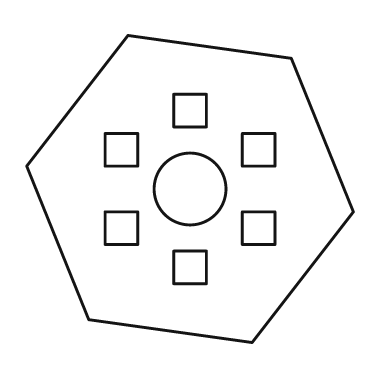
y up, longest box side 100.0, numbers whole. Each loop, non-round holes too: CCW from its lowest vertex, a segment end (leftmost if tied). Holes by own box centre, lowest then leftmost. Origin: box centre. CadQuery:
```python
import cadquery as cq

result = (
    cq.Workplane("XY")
    .moveTo(19.0, -47.0)
    .lineTo(50.0, -7.0)
    .lineTo(31.0, 40.0)
    .lineTo(-19.0, 47.0)
    .lineTo(-50.0, 7.0)
    .lineTo(-31.0, -40.0)
    .close()
    .moveTo(-5.0, -29.0)
    .lineTo(5.0, -29.0)
    .lineTo(5.0, -19.0)
    .lineTo(-5.0, -19.0)
    .close()
    .moveTo(-26.0, -17.0)
    .lineTo(-16.0, -17.0)
    .lineTo(-16.0, -7.0)
    .lineTo(-26.0, -7.0)
    .close()
    .moveTo(16.0, -17.0)
    .lineTo(26.0, -17.0)
    .lineTo(26.0, -7.0)
    .lineTo(16.0, -7.0)
    .close()
    .moveTo(0.0, 0.0)
    .circle(11.0)
    .moveTo(-26.0, 7.0)
    .lineTo(-16.0, 7.0)
    .lineTo(-16.0, 17.0)
    .lineTo(-26.0, 17.0)
    .close()
    .moveTo(16.0, 7.0)
    .lineTo(26.0, 7.0)
    .lineTo(26.0, 17.0)
    .lineTo(16.0, 17.0)
    .close()
    .moveTo(-5.0, 19.0)
    .lineTo(5.0, 19.0)
    .lineTo(5.0, 29.0)
    .lineTo(-5.0, 29.0)
    .close()
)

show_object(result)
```